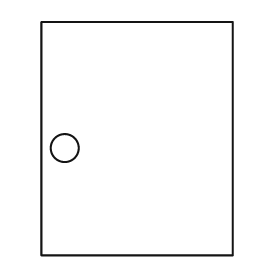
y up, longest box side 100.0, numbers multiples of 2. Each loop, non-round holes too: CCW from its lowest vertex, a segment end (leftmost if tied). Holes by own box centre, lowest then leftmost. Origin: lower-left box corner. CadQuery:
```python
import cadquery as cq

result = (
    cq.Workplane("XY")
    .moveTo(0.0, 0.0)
    .lineTo(82.0, 0.0)
    .lineTo(82.0, 100.0)
    .lineTo(0.0, 100.0)
    .close()
    .moveTo(10.0, 46.0)
    .circle(6.0)
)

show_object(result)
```